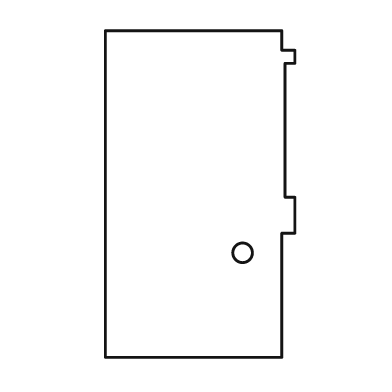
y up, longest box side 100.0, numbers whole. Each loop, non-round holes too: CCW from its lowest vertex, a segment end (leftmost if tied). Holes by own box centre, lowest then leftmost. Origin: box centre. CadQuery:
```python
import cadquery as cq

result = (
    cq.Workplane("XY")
    .moveTo(-29.0, -50.0)
    .lineTo(25.0, -50.0)
    .lineTo(25.0, -12.0)
    .lineTo(29.0, -12.0)
    .lineTo(29.0, -1.0)
    .lineTo(26.0, -1.0)
    .lineTo(26.0, 40.0)
    .lineTo(29.0, 40.0)
    .lineTo(29.0, 44.0)
    .lineTo(25.0, 44.0)
    .lineTo(25.0, 50.0)
    .lineTo(-29.0, 50.0)
    .close()
    .moveTo(13.0, -18.0)
    .circle(3.0)
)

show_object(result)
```